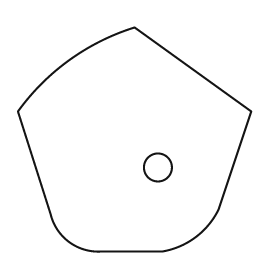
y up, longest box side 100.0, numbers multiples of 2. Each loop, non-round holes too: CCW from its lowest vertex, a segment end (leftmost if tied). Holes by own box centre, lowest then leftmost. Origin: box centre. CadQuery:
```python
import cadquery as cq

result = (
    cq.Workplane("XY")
    .moveTo(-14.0, -48.0)
    .lineTo(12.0, -48.0)
    .threePointArc((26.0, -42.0), (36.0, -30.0))
    .lineTo(50.0, 12.0)
    .lineTo(0.0, 48.0)
    .threePointArc((-28.0, 34.0), (-50.0, 12.0))
    .lineTo(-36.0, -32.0)
    .threePointArc((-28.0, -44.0), (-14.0, -48.0))
    .close()
    .moveTo(10.0, -12.0)
    .circle(6.0)
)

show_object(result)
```